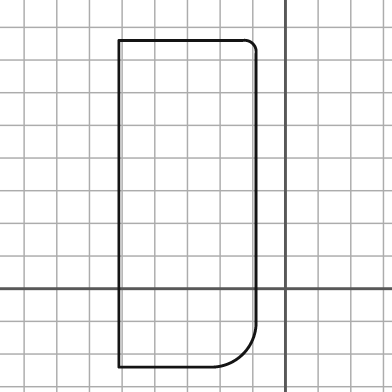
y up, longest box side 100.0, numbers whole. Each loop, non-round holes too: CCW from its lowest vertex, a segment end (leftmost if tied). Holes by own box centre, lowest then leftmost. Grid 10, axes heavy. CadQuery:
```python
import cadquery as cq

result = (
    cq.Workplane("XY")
    .moveTo(-51.0, -24.0)
    .lineTo(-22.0, -24.0)
    .threePointArc((-13.0, -20.0), (-9.0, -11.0))
    .lineTo(-9.0, 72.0)
    .threePointArc((-10.0, 75.0), (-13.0, 76.0))
    .lineTo(-51.0, 76.0)
    .close()
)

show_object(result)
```